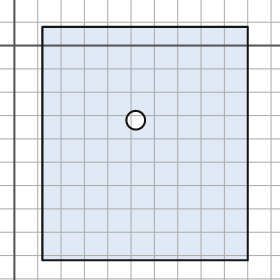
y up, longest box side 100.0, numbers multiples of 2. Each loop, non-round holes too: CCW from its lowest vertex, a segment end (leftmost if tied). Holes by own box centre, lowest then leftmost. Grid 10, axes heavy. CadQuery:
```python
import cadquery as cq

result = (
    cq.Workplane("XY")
    .moveTo(12.0, -92.0)
    .lineTo(100.0, -92.0)
    .lineTo(100.0, 8.0)
    .lineTo(12.0, 8.0)
    .close()
    .moveTo(52.0, -32.0)
    .circle(4.0)
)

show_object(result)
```